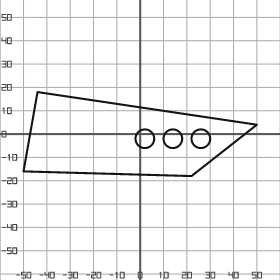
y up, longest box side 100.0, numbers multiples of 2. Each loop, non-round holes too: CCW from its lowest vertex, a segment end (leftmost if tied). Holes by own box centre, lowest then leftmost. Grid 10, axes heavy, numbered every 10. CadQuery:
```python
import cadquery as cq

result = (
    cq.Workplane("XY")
    .moveTo(22.0, -18.0)
    .lineTo(50.0, 4.0)
    .lineTo(-44.0, 18.0)
    .lineTo(-50.0, -16.0)
    .close()
    .moveTo(2.0, -2.0)
    .circle(4.0)
    .moveTo(14.0, -2.0)
    .circle(4.0)
    .moveTo(26.0, -2.0)
    .circle(4.0)
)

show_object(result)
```